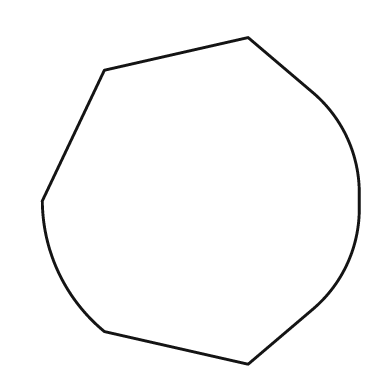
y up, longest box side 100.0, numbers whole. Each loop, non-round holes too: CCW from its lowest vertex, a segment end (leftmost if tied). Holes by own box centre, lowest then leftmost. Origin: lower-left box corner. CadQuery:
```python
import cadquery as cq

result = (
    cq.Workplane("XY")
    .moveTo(63.0, 0.0)
    .lineTo(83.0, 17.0)
    .threePointArc((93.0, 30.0), (97.0, 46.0))
    .lineTo(97.0, 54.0)
    .threePointArc((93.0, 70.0), (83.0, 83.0))
    .lineTo(63.0, 100.0)
    .lineTo(19.0, 90.0)
    .lineTo(0.0, 50.0)
    .threePointArc((5.0, 28.0), (19.0, 10.0))
    .close()
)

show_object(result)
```